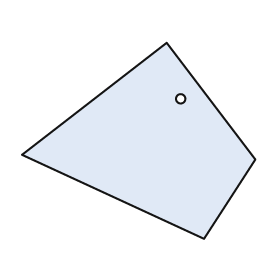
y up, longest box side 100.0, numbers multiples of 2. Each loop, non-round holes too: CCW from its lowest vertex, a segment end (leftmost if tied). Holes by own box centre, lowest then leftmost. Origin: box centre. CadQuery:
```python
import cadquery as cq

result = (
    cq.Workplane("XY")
    .moveTo(28.0, -42.0)
    .lineTo(50.0, -8.0)
    .lineTo(12.0, 42.0)
    .lineTo(-50.0, -6.0)
    .close()
    .moveTo(18.0, 18.0)
    .circle(2.0)
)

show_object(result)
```